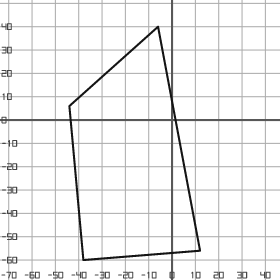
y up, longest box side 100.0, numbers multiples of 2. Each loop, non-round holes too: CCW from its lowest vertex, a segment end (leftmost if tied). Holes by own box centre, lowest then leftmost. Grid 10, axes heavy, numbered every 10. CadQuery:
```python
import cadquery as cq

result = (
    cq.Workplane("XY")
    .moveTo(-38.0, -60.0)
    .lineTo(12.0, -56.0)
    .lineTo(-6.0, 40.0)
    .lineTo(-44.0, 6.0)
    .close()
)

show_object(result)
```